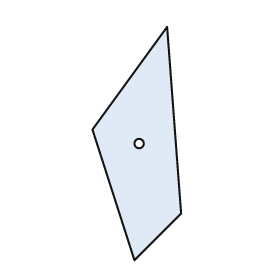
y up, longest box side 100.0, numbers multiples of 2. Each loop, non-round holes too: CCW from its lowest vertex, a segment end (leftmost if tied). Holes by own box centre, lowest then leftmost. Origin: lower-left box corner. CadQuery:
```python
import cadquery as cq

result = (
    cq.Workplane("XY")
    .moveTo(18.0, 0.0)
    .lineTo(38.0, 20.0)
    .lineTo(32.0, 100.0)
    .lineTo(0.0, 56.0)
    .close()
    .moveTo(20.0, 50.0)
    .circle(2.0)
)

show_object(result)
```